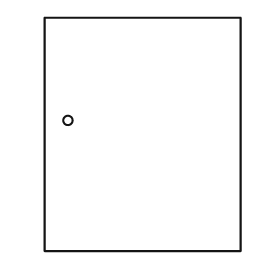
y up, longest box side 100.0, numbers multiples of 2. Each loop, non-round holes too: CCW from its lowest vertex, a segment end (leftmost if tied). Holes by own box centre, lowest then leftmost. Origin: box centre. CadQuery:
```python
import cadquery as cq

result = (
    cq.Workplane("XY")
    .moveTo(-42.0, -50.0)
    .lineTo(42.0, -50.0)
    .lineTo(42.0, 50.0)
    .lineTo(-42.0, 50.0)
    .close()
    .moveTo(-32.0, 6.0)
    .circle(2.0)
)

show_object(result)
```